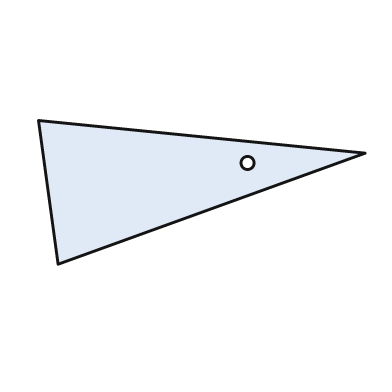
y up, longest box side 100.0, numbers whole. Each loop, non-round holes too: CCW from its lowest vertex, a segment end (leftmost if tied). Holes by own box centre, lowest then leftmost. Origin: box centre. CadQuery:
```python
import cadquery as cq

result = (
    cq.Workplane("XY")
    .moveTo(-44.0, -22.0)
    .lineTo(50.0, 12.0)
    .lineTo(-50.0, 22.0)
    .close()
    .moveTo(14.0, 9.0)
    .circle(2.0)
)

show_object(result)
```